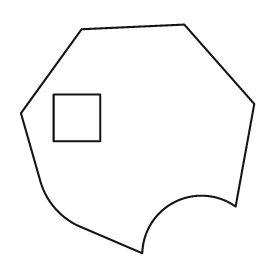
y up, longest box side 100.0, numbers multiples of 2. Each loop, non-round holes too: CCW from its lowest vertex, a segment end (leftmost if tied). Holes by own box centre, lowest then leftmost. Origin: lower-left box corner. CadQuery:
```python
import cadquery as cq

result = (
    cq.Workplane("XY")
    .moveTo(52.0, 0.0)
    .threePointArc((66.0, 22.0), (92.0, 20.0))
    .lineTo(100.0, 64.0)
    .lineTo(70.0, 98.0)
    .lineTo(26.0, 96.0)
    .lineTo(0.0, 60.0)
    .lineTo(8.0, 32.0)
    .threePointArc((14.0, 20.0), (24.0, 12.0))
    .close()
    .moveTo(14.0, 48.0)
    .lineTo(34.0, 48.0)
    .lineTo(34.0, 68.0)
    .lineTo(14.0, 68.0)
    .close()
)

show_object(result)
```